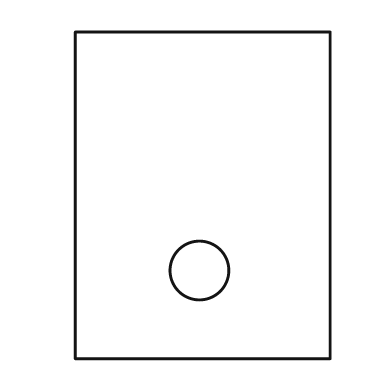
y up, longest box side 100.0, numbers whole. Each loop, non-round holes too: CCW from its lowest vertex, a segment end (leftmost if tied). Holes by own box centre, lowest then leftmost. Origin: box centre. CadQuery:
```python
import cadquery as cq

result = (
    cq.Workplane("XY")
    .moveTo(-39.0, -50.0)
    .lineTo(39.0, -50.0)
    .lineTo(39.0, 50.0)
    .lineTo(-39.0, 50.0)
    .close()
    .moveTo(-1.0, -23.0)
    .circle(9.0)
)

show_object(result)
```